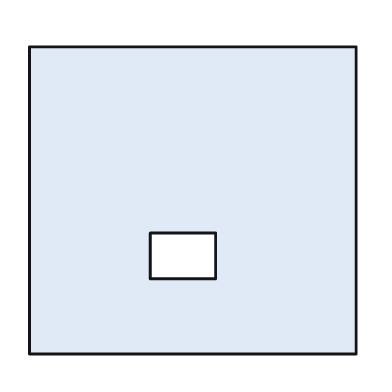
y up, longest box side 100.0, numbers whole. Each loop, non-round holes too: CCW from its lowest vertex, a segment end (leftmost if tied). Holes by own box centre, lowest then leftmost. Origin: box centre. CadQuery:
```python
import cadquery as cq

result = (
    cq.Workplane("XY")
    .moveTo(-50.0, -47.0)
    .lineTo(50.0, -47.0)
    .lineTo(50.0, 47.0)
    .lineTo(-50.0, 47.0)
    .close()
    .moveTo(-13.0, -24.0)
    .lineTo(7.0, -24.0)
    .lineTo(7.0, -10.0)
    .lineTo(-13.0, -10.0)
    .close()
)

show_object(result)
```